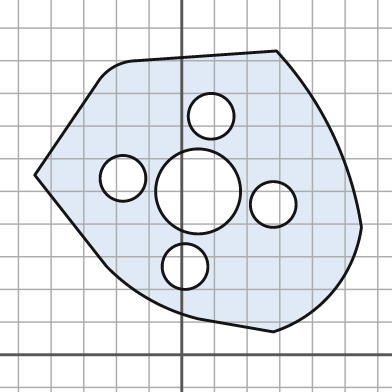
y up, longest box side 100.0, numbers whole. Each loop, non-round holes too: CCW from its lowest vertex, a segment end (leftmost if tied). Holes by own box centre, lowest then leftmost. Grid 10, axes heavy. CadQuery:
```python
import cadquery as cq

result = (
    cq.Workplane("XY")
    .moveTo(28.0, 7.0)
    .threePointArc((46.0, 19.0), (55.0, 39.0))
    .threePointArc((46.0, 68.0), (29.0, 93.0))
    .lineTo(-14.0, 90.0)
    .threePointArc((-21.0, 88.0), (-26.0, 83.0))
    .lineTo(-45.0, 55.0)
    .lineTo(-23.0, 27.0)
    .threePointArc((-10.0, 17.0), (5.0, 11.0))
    .close()
    .moveTo(1.0, 27.0)
    .circle(7.0)
    .moveTo(28.0, 46.0)
    .circle(7.0)
    .moveTo(5.0, 50.0)
    .circle(13.0)
    .moveTo(-18.0, 54.0)
    .circle(7.0)
    .moveTo(9.0, 73.0)
    .circle(7.0)
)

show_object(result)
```